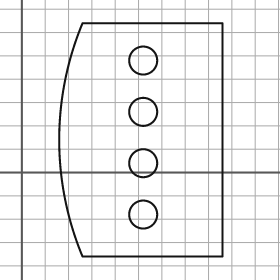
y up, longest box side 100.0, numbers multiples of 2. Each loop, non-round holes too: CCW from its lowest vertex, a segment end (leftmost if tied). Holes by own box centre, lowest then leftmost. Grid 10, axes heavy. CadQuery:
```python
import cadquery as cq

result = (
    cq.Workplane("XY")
    .moveTo(26.0, -36.0)
    .lineTo(86.0, -36.0)
    .lineTo(86.0, 64.0)
    .lineTo(26.0, 64.0)
    .threePointArc((16.0, 14.0), (26.0, -36.0))
    .close()
    .moveTo(52.0, -18.0)
    .circle(6.0)
    .moveTo(52.0, 4.0)
    .circle(6.0)
    .moveTo(52.0, 26.0)
    .circle(6.0)
    .moveTo(52.0, 48.0)
    .circle(6.0)
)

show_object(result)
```